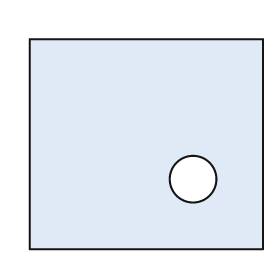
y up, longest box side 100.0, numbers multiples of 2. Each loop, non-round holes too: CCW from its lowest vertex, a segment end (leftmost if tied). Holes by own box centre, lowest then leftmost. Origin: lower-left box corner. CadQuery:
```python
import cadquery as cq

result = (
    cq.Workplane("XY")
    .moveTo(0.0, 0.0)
    .lineTo(100.0, 0.0)
    .lineTo(100.0, 90.0)
    .lineTo(0.0, 90.0)
    .close()
    .moveTo(70.0, 30.0)
    .circle(10.0)
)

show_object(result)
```